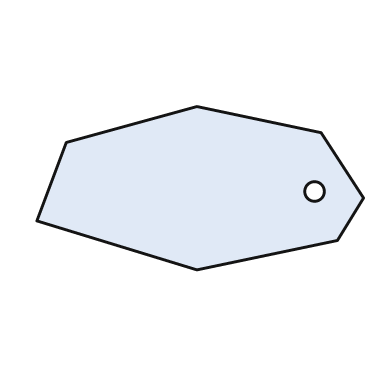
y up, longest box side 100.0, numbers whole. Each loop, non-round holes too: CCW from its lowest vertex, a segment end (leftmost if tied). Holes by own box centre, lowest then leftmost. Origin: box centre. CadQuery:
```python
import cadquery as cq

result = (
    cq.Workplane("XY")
    .moveTo(-1.0, -25.0)
    .lineTo(42.0, -16.0)
    .lineTo(50.0, -3.0)
    .lineTo(37.0, 17.0)
    .lineTo(-1.0, 25.0)
    .lineTo(-41.0, 14.0)
    .lineTo(-50.0, -10.0)
    .close()
    .moveTo(35.0, -1.0)
    .circle(3.0)
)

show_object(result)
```